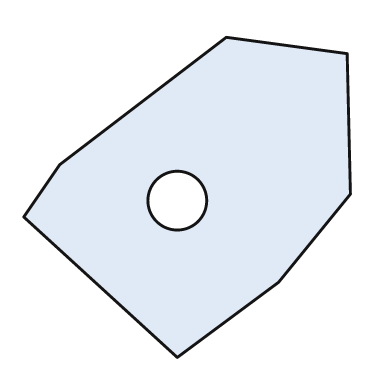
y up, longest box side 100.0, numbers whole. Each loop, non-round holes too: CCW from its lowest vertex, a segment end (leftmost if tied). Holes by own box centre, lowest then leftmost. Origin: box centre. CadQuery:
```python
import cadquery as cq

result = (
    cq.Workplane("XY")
    .moveTo(-3.0, -49.0)
    .lineTo(28.0, -26.0)
    .lineTo(50.0, 1.0)
    .lineTo(49.0, 44.0)
    .lineTo(12.0, 49.0)
    .lineTo(-39.0, 10.0)
    .lineTo(-50.0, -6.0)
    .close()
    .moveTo(-3.0, -1.0)
    .circle(9.0)
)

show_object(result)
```